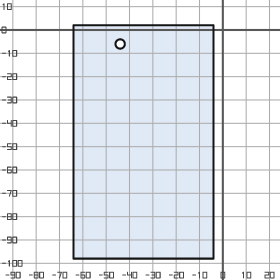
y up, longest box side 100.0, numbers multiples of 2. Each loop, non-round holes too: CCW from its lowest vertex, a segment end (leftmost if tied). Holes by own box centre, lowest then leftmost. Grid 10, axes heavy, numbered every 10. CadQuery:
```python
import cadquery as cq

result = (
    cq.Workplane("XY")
    .moveTo(-64.0, -98.0)
    .lineTo(-4.0, -98.0)
    .lineTo(-4.0, 2.0)
    .lineTo(-64.0, 2.0)
    .close()
    .moveTo(-44.0, -6.0)
    .circle(2.0)
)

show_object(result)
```